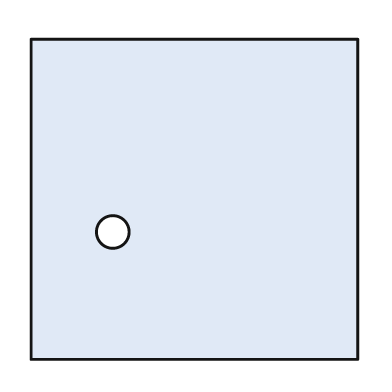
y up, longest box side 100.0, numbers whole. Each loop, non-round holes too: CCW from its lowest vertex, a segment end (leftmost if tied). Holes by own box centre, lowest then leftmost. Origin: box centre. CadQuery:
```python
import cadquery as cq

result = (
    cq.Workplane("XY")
    .moveTo(-50.0, -49.0)
    .lineTo(50.0, -49.0)
    .lineTo(50.0, 49.0)
    .lineTo(-50.0, 49.0)
    .close()
    .moveTo(-25.0, -10.0)
    .circle(5.0)
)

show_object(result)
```